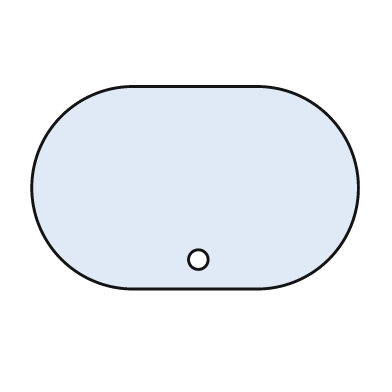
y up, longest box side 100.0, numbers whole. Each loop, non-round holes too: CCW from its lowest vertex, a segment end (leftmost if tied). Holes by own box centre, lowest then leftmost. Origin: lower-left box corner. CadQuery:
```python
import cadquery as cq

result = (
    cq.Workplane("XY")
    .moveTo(31.0, 0.0)
    .lineTo(69.0, 0.0)
    .threePointArc((100.0, 31.0), (69.0, 62.0))
    .lineTo(31.0, 62.0)
    .threePointArc((0.0, 31.0), (31.0, 0.0))
    .close()
    .moveTo(51.0, 9.0)
    .circle(3.0)
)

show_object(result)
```